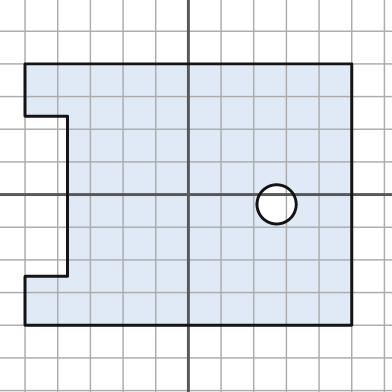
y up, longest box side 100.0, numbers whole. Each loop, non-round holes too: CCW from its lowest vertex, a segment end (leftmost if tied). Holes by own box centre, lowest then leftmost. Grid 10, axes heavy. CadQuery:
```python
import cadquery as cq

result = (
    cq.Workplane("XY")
    .moveTo(-50.0, -40.0)
    .lineTo(50.0, -40.0)
    .lineTo(50.0, 40.0)
    .lineTo(-50.0, 40.0)
    .lineTo(-50.0, 24.0)
    .lineTo(-37.0, 24.0)
    .lineTo(-37.0, -25.0)
    .lineTo(-50.0, -25.0)
    .close()
    .moveTo(27.0, -3.0)
    .circle(6.0)
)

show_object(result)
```